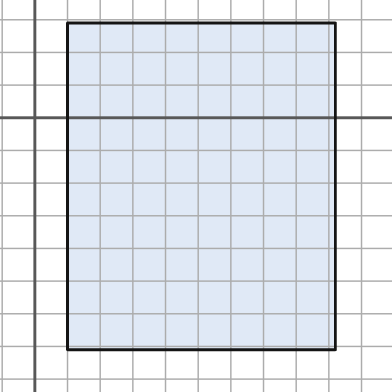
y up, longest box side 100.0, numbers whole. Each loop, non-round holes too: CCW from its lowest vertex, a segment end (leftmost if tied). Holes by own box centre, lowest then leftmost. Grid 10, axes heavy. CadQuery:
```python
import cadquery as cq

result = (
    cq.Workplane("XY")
    .moveTo(10.0, -71.0)
    .lineTo(92.0, -71.0)
    .lineTo(92.0, 29.0)
    .lineTo(10.0, 29.0)
    .close()
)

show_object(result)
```